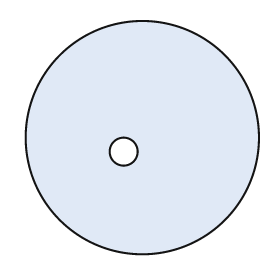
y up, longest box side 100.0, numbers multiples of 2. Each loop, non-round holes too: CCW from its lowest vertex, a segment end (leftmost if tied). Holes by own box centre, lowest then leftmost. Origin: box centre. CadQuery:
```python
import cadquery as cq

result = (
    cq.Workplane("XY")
    .moveTo(0.0, 0.0)
    .circle(50.0)
    .moveTo(-8.0, -6.0)
    .circle(6.0)
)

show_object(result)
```